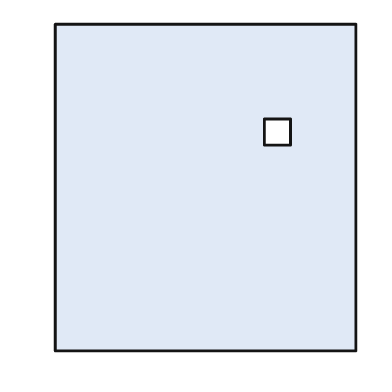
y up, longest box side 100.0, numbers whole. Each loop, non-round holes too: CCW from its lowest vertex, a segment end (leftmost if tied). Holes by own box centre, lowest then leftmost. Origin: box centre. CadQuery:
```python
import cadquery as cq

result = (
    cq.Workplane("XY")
    .moveTo(-46.0, -50.0)
    .lineTo(46.0, -50.0)
    .lineTo(46.0, 50.0)
    .lineTo(-46.0, 50.0)
    .close()
    .moveTo(18.0, 13.0)
    .lineTo(26.0, 13.0)
    .lineTo(26.0, 21.0)
    .lineTo(18.0, 21.0)
    .close()
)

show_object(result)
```